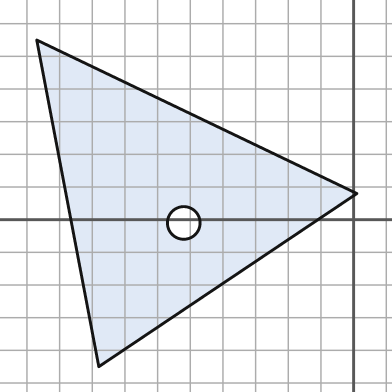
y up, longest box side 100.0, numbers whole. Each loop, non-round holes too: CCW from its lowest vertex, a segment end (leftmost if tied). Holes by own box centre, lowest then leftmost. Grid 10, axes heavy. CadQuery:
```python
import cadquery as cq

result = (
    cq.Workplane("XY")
    .moveTo(-78.0, -45.0)
    .lineTo(1.0, 8.0)
    .lineTo(-97.0, 55.0)
    .close()
    .moveTo(-52.0, -1.0)
    .circle(5.0)
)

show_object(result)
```